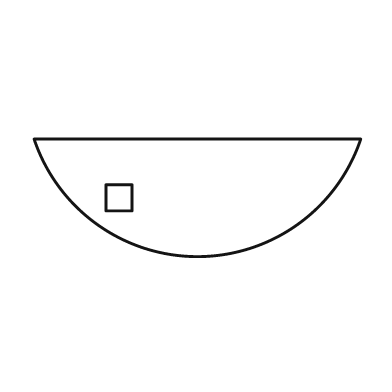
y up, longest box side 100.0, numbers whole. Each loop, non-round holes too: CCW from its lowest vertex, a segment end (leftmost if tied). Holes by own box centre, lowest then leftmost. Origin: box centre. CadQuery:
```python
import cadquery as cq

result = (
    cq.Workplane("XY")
    .moveTo(-50.0, 18.0)
    .threePointArc((0.0, -18.0), (50.0, 18.0))
    .close()
    .moveTo(-28.0, -4.0)
    .lineTo(-20.0, -4.0)
    .lineTo(-20.0, 4.0)
    .lineTo(-28.0, 4.0)
    .close()
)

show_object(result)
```